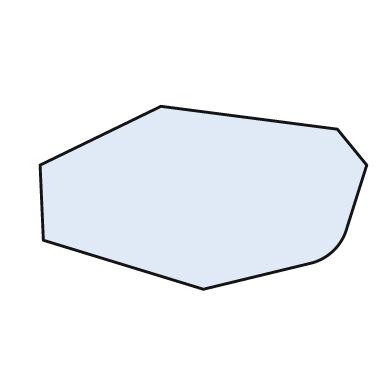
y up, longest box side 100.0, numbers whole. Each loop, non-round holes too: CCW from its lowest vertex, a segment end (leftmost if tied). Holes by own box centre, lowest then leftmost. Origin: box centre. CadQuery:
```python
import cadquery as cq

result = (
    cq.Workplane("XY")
    .moveTo(0.0, -28.0)
    .lineTo(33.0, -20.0)
    .threePointArc((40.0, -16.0), (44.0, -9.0))
    .lineTo(50.0, 10.0)
    .lineTo(41.0, 21.0)
    .lineTo(-13.0, 28.0)
    .lineTo(-50.0, 10.0)
    .lineTo(-49.0, -13.0)
    .close()
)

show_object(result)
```